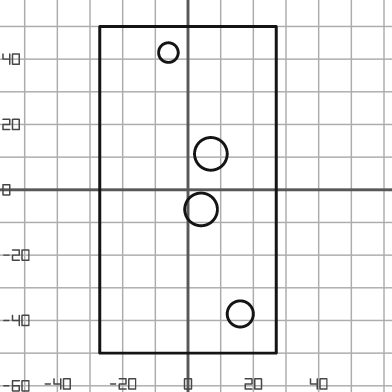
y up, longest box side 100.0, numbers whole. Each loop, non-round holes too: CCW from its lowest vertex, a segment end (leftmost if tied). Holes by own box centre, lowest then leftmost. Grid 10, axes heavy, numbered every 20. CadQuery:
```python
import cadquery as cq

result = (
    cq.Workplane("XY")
    .moveTo(-27.0, -50.0)
    .lineTo(27.0, -50.0)
    .lineTo(27.0, 50.0)
    .lineTo(-27.0, 50.0)
    .close()
    .moveTo(16.0, -38.0)
    .circle(4.0)
    .moveTo(4.0, -6.0)
    .circle(5.0)
    .moveTo(7.0, 11.0)
    .circle(5.0)
    .moveTo(-6.0, 42.0)
    .circle(3.0)
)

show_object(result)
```